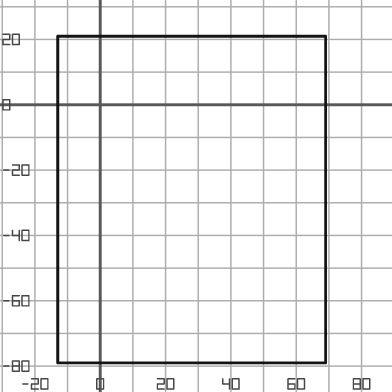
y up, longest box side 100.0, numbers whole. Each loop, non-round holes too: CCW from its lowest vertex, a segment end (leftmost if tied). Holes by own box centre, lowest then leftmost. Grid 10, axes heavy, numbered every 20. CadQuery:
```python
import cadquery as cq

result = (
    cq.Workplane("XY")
    .moveTo(-13.0, -79.0)
    .lineTo(69.0, -79.0)
    .lineTo(69.0, 21.0)
    .lineTo(-13.0, 21.0)
    .close()
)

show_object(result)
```